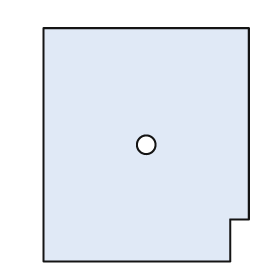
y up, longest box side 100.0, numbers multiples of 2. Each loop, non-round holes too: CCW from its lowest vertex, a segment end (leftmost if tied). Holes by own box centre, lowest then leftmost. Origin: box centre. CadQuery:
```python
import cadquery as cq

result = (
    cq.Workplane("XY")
    .moveTo(-44.0, -50.0)
    .lineTo(36.0, -50.0)
    .lineTo(36.0, -32.0)
    .lineTo(44.0, -32.0)
    .lineTo(44.0, 50.0)
    .lineTo(-44.0, 50.0)
    .close()
    .moveTo(0.0, 0.0)
    .circle(4.0)
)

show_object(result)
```